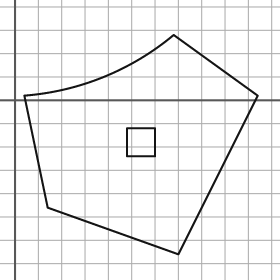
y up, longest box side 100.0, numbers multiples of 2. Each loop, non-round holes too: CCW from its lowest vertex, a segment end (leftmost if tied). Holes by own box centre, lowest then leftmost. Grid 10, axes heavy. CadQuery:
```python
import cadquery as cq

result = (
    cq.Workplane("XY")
    .moveTo(70.0, -66.0)
    .lineTo(104.0, 2.0)
    .lineTo(68.0, 28.0)
    .threePointArc((38.0, 10.0), (4.0, 2.0))
    .lineTo(14.0, -46.0)
    .close()
    .moveTo(48.0, -24.0)
    .lineTo(60.0, -24.0)
    .lineTo(60.0, -12.0)
    .lineTo(48.0, -12.0)
    .close()
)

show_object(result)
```